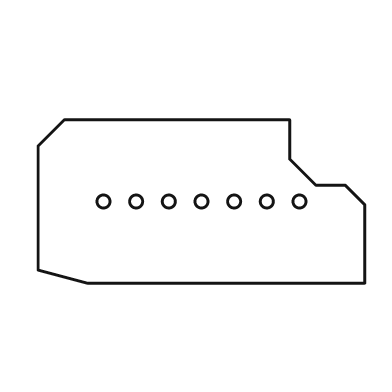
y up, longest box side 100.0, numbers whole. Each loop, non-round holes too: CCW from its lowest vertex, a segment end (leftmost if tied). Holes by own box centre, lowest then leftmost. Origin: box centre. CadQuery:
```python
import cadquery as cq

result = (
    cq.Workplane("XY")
    .moveTo(-35.0, -25.0)
    .lineTo(50.0, -25.0)
    .lineTo(50.0, -1.0)
    .lineTo(44.0, 5.0)
    .lineTo(35.0, 5.0)
    .lineTo(27.0, 13.0)
    .lineTo(27.0, 25.0)
    .lineTo(-42.0, 25.0)
    .lineTo(-50.0, 17.0)
    .lineTo(-50.0, -21.0)
    .close()
    .moveTo(-30.0, 0.0)
    .circle(2.0)
    .moveTo(-20.0, 0.0)
    .circle(2.0)
    .moveTo(-10.0, 0.0)
    .circle(2.0)
    .moveTo(0.0, 0.0)
    .circle(2.0)
    .moveTo(10.0, 0.0)
    .circle(2.0)
    .moveTo(20.0, 0.0)
    .circle(2.0)
    .moveTo(30.0, 0.0)
    .circle(2.0)
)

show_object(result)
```